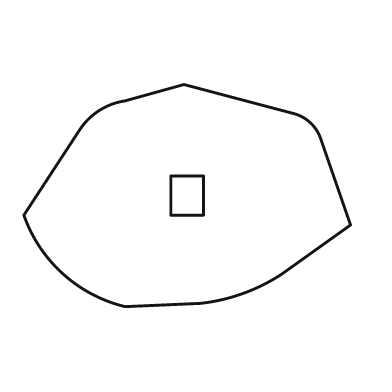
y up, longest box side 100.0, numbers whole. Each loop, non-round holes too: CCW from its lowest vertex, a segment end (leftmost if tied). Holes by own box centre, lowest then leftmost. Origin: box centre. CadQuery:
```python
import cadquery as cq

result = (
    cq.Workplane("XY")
    .moveTo(-19.0, -34.0)
    .lineTo(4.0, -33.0)
    .threePointArc((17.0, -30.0), (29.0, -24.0))
    .lineTo(50.0, -9.0)
    .lineTo(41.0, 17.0)
    .threePointArc((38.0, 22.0), (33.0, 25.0))
    .lineTo(-1.0, 34.0)
    .lineTo(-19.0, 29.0)
    .threePointArc((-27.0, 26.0), (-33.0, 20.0))
    .lineTo(-50.0, -6.0)
    .threePointArc((-38.0, -24.0), (-19.0, -34.0))
    .close()
    .moveTo(-5.0, -6.0)
    .lineTo(5.0, -6.0)
    .lineTo(5.0, 6.0)
    .lineTo(-5.0, 6.0)
    .close()
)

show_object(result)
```